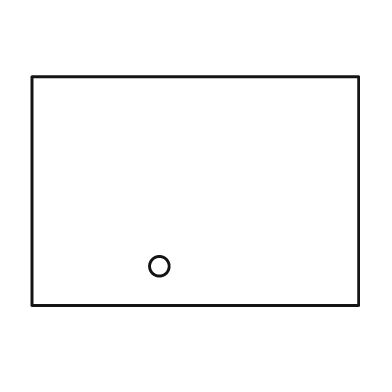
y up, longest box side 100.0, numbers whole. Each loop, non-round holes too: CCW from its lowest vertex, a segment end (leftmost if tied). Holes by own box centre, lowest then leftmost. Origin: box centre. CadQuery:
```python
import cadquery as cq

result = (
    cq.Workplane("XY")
    .moveTo(-50.0, -35.0)
    .lineTo(50.0, -35.0)
    .lineTo(50.0, 35.0)
    .lineTo(-50.0, 35.0)
    .close()
    .moveTo(-11.0, -23.0)
    .circle(3.0)
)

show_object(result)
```